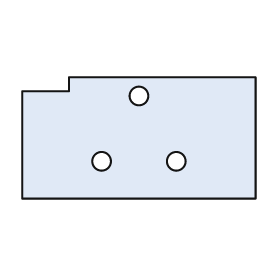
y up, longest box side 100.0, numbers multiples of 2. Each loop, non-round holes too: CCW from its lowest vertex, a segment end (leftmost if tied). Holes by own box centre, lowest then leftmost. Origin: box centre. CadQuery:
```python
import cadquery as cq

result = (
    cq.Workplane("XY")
    .moveTo(-50.0, -26.0)
    .lineTo(50.0, -26.0)
    .lineTo(50.0, 26.0)
    .lineTo(-30.0, 26.0)
    .lineTo(-30.0, 20.0)
    .lineTo(-50.0, 20.0)
    .close()
    .moveTo(-16.0, -10.0)
    .circle(4.0)
    .moveTo(16.0, -10.0)
    .circle(4.0)
    .moveTo(0.0, 18.0)
    .circle(4.0)
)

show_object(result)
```